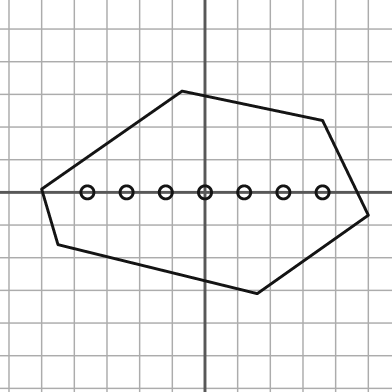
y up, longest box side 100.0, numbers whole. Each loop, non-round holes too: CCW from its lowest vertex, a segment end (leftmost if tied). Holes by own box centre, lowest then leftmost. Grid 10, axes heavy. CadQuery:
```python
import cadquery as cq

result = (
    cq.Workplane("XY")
    .moveTo(16.0, -31.0)
    .lineTo(50.0, -7.0)
    .lineTo(36.0, 22.0)
    .lineTo(-7.0, 31.0)
    .lineTo(-50.0, 1.0)
    .lineTo(-45.0, -16.0)
    .close()
    .moveTo(-36.0, 0.0)
    .circle(2.0)
    .moveTo(-24.0, 0.0)
    .circle(2.0)
    .moveTo(-12.0, 0.0)
    .circle(2.0)
    .moveTo(0.0, 0.0)
    .circle(2.0)
    .moveTo(12.0, 0.0)
    .circle(2.0)
    .moveTo(24.0, 0.0)
    .circle(2.0)
    .moveTo(36.0, 0.0)
    .circle(2.0)
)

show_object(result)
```